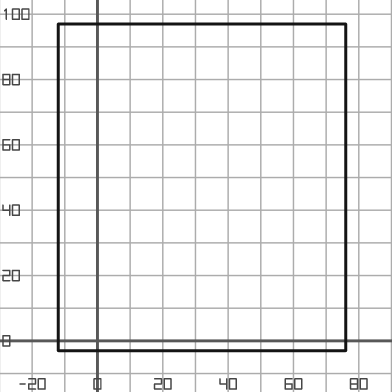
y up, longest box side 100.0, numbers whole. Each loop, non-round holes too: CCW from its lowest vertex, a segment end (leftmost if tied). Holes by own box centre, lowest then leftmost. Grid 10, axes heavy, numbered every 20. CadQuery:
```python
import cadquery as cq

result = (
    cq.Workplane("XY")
    .moveTo(-12.0, -3.0)
    .lineTo(76.0, -3.0)
    .lineTo(76.0, 97.0)
    .lineTo(-12.0, 97.0)
    .close()
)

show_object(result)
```